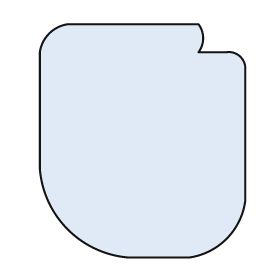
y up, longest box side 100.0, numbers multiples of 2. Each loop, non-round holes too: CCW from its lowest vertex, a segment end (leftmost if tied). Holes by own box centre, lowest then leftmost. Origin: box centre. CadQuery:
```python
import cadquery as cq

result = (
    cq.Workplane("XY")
    .moveTo(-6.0, -50.0)
    .lineTo(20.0, -50.0)
    .threePointArc((36.0, -42.0), (44.0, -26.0))
    .lineTo(44.0, 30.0)
    .threePointArc((42.0, 36.0), (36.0, 38.0))
    .lineTo(24.0, 38.0)
    .threePointArc((26.0, 44.0), (24.0, 50.0))
    .lineTo(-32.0, 50.0)
    .threePointArc((-40.0, 46.0), (-44.0, 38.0))
    .lineTo(-44.0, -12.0)
    .threePointArc((-32.0, -38.0), (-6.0, -50.0))
    .close()
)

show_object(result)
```